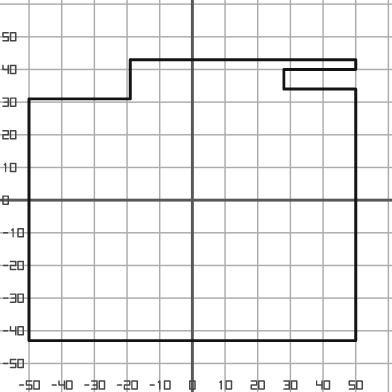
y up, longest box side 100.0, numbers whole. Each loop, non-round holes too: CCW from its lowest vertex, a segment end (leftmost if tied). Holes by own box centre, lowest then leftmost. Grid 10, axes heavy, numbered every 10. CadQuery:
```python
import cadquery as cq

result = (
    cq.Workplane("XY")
    .moveTo(-50.0, -43.0)
    .lineTo(50.0, -43.0)
    .lineTo(50.0, 34.0)
    .lineTo(28.0, 34.0)
    .lineTo(28.0, 40.0)
    .lineTo(50.0, 40.0)
    .lineTo(50.0, 43.0)
    .lineTo(-19.0, 43.0)
    .lineTo(-19.0, 31.0)
    .lineTo(-50.0, 31.0)
    .close()
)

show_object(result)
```